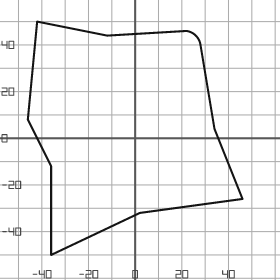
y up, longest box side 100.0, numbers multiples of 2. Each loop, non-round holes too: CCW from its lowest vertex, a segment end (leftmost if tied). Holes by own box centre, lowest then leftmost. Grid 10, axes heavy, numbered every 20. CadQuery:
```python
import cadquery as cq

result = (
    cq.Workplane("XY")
    .moveTo(-36.0, -50.0)
    .lineTo(2.0, -32.0)
    .lineTo(46.0, -26.0)
    .lineTo(34.0, 4.0)
    .lineTo(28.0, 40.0)
    .threePointArc((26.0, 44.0), (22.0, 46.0))
    .lineTo(-12.0, 44.0)
    .lineTo(-42.0, 50.0)
    .lineTo(-46.0, 8.0)
    .lineTo(-36.0, -12.0)
    .close()
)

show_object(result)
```